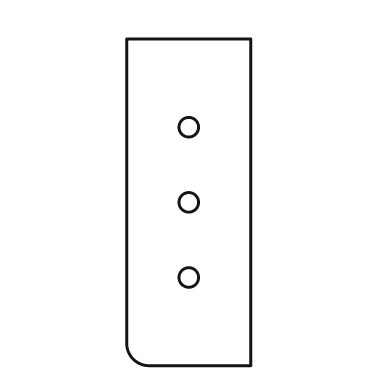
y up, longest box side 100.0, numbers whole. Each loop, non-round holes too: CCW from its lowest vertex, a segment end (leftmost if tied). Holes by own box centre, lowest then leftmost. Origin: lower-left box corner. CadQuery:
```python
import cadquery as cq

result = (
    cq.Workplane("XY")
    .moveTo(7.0, 0.0)
    .lineTo(38.0, 0.0)
    .lineTo(38.0, 100.0)
    .lineTo(0.0, 100.0)
    .lineTo(0.0, 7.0)
    .threePointArc((2.0, 2.0), (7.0, 0.0))
    .close()
    .moveTo(19.0, 27.0)
    .circle(3.0)
    .moveTo(19.0, 50.0)
    .circle(3.0)
    .moveTo(19.0, 73.0)
    .circle(3.0)
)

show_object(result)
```